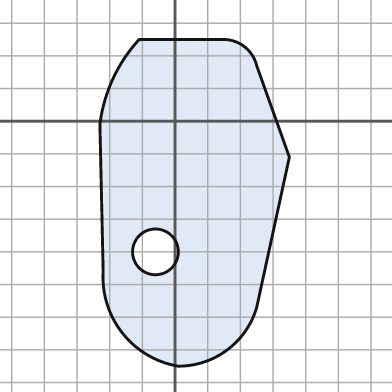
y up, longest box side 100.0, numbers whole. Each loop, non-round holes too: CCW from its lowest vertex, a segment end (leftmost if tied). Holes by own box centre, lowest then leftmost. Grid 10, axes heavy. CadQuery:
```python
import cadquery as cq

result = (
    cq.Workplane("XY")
    .moveTo(1.0, -75.0)
    .threePointArc((16.0, -70.0), (25.0, -57.0))
    .lineTo(35.0, -11.0)
    .lineTo(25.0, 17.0)
    .threePointArc((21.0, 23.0), (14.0, 25.0))
    .lineTo(-11.0, 25.0)
    .threePointArc((-19.0, 13.0), (-23.0, -1.0))
    .lineTo(-22.0, -46.0)
    .threePointArc((-16.0, -65.0), (1.0, -75.0))
    .close()
    .moveTo(-6.0, -40.0)
    .circle(7.0)
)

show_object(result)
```